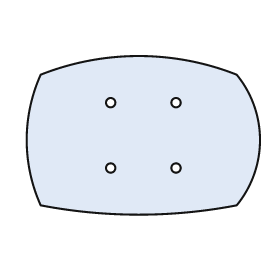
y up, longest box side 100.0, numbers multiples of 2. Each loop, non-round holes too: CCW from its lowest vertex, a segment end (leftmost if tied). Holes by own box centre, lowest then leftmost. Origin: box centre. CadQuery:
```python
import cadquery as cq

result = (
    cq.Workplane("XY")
    .moveTo(-44.0, -30.0)
    .threePointArc((-2.0, -34.0), (40.0, -30.0))
    .threePointArc((50.0, -2.0), (40.0, 26.0))
    .threePointArc((-2.0, 34.0), (-44.0, 26.0))
    .threePointArc((-50.0, -2.0), (-44.0, -30.0))
    .close()
    .moveTo(-14.0, -14.0)
    .circle(2.0)
    .moveTo(14.0, -14.0)
    .circle(2.0)
    .moveTo(-14.0, 14.0)
    .circle(2.0)
    .moveTo(14.0, 14.0)
    .circle(2.0)
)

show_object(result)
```